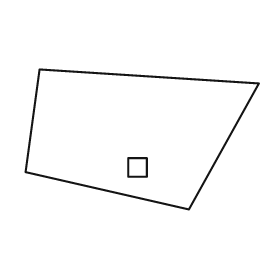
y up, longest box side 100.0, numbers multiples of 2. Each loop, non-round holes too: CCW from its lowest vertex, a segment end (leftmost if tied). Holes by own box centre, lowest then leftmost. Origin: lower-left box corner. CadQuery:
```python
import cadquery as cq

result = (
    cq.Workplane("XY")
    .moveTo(70.0, 0.0)
    .lineTo(100.0, 54.0)
    .lineTo(6.0, 60.0)
    .lineTo(0.0, 16.0)
    .close()
    .moveTo(44.0, 14.0)
    .lineTo(52.0, 14.0)
    .lineTo(52.0, 22.0)
    .lineTo(44.0, 22.0)
    .close()
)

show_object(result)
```